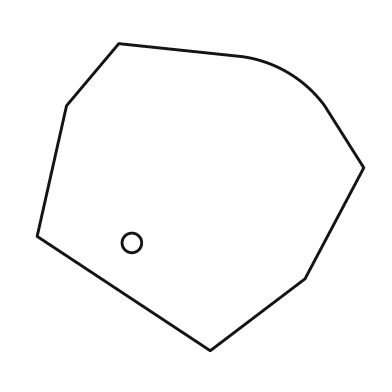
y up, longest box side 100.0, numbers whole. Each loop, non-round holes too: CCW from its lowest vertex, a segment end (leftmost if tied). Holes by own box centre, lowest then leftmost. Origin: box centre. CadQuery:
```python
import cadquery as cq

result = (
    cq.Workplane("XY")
    .moveTo(3.0, -47.0)
    .lineTo(32.0, -25.0)
    .lineTo(50.0, 9.0)
    .lineTo(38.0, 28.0)
    .threePointArc((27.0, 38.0), (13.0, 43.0))
    .lineTo(-25.0, 47.0)
    .lineTo(-41.0, 28.0)
    .lineTo(-50.0, -12.0)
    .close()
    .moveTo(-21.0, -14.0)
    .circle(3.0)
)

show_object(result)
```